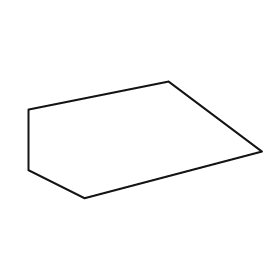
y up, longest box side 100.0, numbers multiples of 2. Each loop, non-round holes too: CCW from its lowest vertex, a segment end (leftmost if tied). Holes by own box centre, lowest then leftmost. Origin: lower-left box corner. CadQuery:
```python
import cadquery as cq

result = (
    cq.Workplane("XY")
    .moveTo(24.0, 0.0)
    .lineTo(100.0, 20.0)
    .lineTo(60.0, 50.0)
    .lineTo(0.0, 38.0)
    .lineTo(0.0, 12.0)
    .close()
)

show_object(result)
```